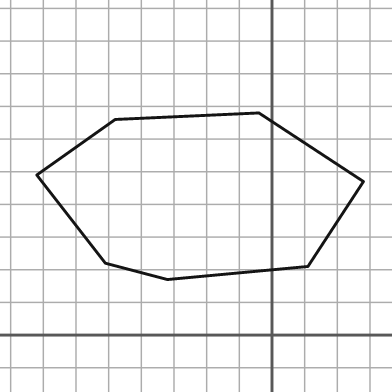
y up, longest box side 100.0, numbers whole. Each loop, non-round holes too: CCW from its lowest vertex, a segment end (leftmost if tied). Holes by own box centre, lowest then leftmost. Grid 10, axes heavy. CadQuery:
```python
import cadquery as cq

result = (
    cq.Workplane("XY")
    .moveTo(-32.0, 17.0)
    .lineTo(11.0, 21.0)
    .lineTo(28.0, 47.0)
    .lineTo(-4.0, 68.0)
    .lineTo(-48.0, 66.0)
    .lineTo(-72.0, 49.0)
    .lineTo(-51.0, 22.0)
    .close()
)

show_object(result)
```